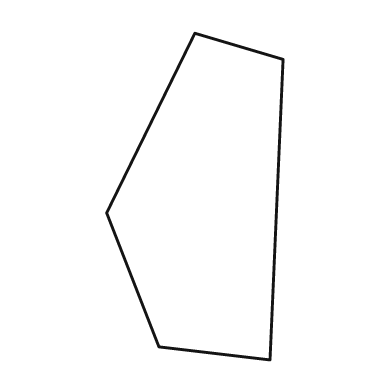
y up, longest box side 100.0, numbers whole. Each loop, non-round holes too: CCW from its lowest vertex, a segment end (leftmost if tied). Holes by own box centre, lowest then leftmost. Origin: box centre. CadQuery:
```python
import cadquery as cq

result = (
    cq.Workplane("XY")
    .moveTo(23.0, -50.0)
    .lineTo(27.0, 42.0)
    .lineTo(0.0, 50.0)
    .lineTo(-27.0, -5.0)
    .lineTo(-11.0, -46.0)
    .close()
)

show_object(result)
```